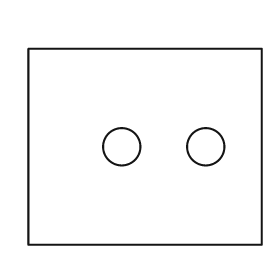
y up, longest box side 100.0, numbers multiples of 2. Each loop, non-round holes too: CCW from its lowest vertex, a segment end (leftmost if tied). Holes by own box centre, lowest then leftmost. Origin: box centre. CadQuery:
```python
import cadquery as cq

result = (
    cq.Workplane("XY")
    .moveTo(-50.0, -42.0)
    .lineTo(50.0, -42.0)
    .lineTo(50.0, 42.0)
    .lineTo(-50.0, 42.0)
    .close()
    .moveTo(-10.0, 0.0)
    .circle(8.0)
    .moveTo(26.0, 0.0)
    .circle(8.0)
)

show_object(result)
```